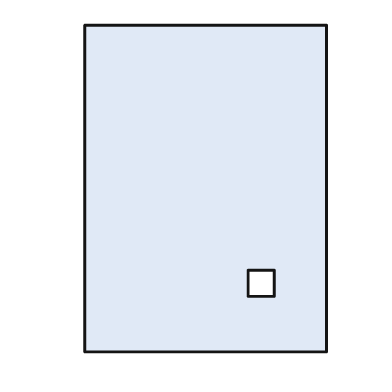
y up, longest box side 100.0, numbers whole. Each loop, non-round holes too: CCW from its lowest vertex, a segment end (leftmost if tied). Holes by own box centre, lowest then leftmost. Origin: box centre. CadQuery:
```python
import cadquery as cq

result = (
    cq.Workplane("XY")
    .moveTo(-37.0, -50.0)
    .lineTo(37.0, -50.0)
    .lineTo(37.0, 50.0)
    .lineTo(-37.0, 50.0)
    .close()
    .moveTo(13.0, -33.0)
    .lineTo(21.0, -33.0)
    .lineTo(21.0, -25.0)
    .lineTo(13.0, -25.0)
    .close()
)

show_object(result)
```